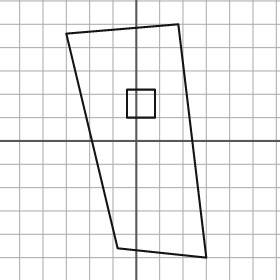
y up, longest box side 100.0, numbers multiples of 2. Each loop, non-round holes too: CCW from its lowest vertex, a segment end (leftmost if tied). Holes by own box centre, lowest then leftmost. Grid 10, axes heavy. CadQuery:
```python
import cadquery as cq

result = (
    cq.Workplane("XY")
    .moveTo(30.0, -50.0)
    .lineTo(18.0, 50.0)
    .lineTo(-30.0, 46.0)
    .lineTo(-8.0, -46.0)
    .close()
    .moveTo(-4.0, 10.0)
    .lineTo(8.0, 10.0)
    .lineTo(8.0, 22.0)
    .lineTo(-4.0, 22.0)
    .close()
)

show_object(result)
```